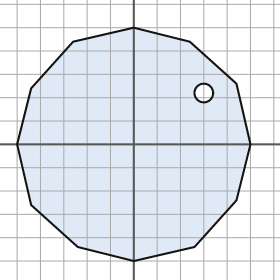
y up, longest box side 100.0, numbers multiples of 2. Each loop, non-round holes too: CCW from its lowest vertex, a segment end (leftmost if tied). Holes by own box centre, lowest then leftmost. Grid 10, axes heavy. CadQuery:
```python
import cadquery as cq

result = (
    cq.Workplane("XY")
    .moveTo(0.0, -50.0)
    .lineTo(26.0, -44.0)
    .lineTo(44.0, -24.0)
    .lineTo(50.0, 0.0)
    .lineTo(44.0, 26.0)
    .lineTo(24.0, 44.0)
    .lineTo(0.0, 50.0)
    .lineTo(-26.0, 44.0)
    .lineTo(-44.0, 24.0)
    .lineTo(-50.0, 0.0)
    .lineTo(-44.0, -26.0)
    .lineTo(-24.0, -44.0)
    .close()
    .moveTo(30.0, 22.0)
    .circle(4.0)
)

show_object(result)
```